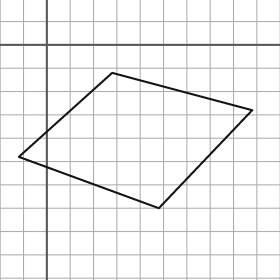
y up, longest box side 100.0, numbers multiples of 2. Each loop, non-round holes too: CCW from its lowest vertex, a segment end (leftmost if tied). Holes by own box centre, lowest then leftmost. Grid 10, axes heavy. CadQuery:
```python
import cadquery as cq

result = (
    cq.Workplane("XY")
    .moveTo(48.0, -70.0)
    .lineTo(88.0, -28.0)
    .lineTo(28.0, -12.0)
    .lineTo(-12.0, -48.0)
    .close()
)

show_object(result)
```